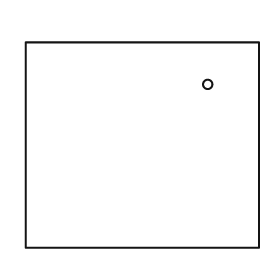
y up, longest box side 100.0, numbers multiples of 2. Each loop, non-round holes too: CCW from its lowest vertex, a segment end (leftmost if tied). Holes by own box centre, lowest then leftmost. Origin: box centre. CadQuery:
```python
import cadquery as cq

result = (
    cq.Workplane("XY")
    .moveTo(-50.0, -44.0)
    .lineTo(50.0, -44.0)
    .lineTo(50.0, 44.0)
    .lineTo(-50.0, 44.0)
    .close()
    .moveTo(28.0, 26.0)
    .circle(2.0)
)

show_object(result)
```